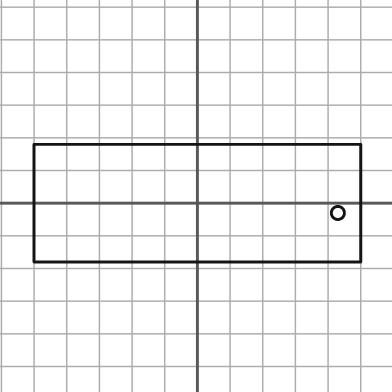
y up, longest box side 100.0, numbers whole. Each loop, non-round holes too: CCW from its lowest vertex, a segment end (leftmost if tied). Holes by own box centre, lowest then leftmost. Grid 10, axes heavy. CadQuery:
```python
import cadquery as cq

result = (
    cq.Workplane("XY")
    .moveTo(-50.0, -18.0)
    .lineTo(50.0, -18.0)
    .lineTo(50.0, 18.0)
    .lineTo(-50.0, 18.0)
    .close()
    .moveTo(43.0, -3.0)
    .circle(2.0)
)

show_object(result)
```